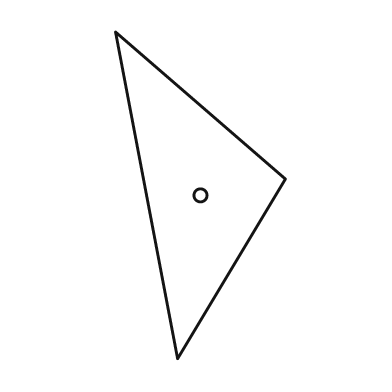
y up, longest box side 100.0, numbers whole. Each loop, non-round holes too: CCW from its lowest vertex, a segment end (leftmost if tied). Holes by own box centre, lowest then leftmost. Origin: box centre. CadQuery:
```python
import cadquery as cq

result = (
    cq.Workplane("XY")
    .moveTo(-7.0, -50.0)
    .lineTo(26.0, 5.0)
    .lineTo(-26.0, 50.0)
    .close()
    .moveTo(0.0, 0.0)
    .circle(2.0)
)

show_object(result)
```